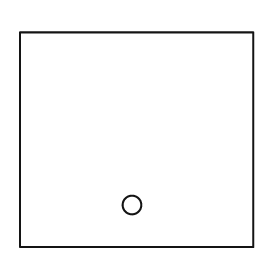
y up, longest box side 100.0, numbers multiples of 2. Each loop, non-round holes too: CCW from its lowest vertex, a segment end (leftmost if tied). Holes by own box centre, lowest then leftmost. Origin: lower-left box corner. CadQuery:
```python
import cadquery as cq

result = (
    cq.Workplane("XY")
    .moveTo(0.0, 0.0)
    .lineTo(100.0, 0.0)
    .lineTo(100.0, 92.0)
    .lineTo(0.0, 92.0)
    .close()
    .moveTo(48.0, 18.0)
    .circle(4.0)
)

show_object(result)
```